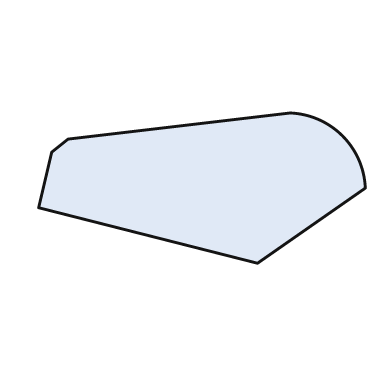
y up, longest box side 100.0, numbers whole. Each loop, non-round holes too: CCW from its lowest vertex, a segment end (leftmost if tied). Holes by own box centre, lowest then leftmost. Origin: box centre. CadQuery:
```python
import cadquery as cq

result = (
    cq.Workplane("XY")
    .moveTo(17.0, -23.0)
    .lineTo(50.0, 0.0)
    .threePointArc((43.0, 16.0), (27.0, 23.0))
    .lineTo(-41.0, 15.0)
    .lineTo(-46.0, 11.0)
    .lineTo(-50.0, -6.0)
    .close()
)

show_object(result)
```